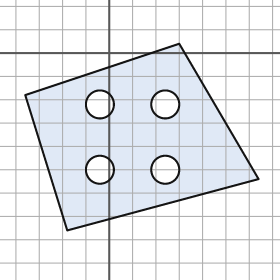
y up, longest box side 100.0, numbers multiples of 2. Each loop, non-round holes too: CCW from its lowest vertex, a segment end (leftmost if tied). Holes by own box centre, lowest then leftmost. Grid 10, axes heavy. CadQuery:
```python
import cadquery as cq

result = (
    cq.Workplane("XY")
    .moveTo(-18.0, -76.0)
    .lineTo(64.0, -54.0)
    .lineTo(30.0, 4.0)
    .lineTo(-36.0, -18.0)
    .close()
    .moveTo(-4.0, -50.0)
    .circle(6.0)
    .moveTo(24.0, -50.0)
    .circle(6.0)
    .moveTo(-4.0, -22.0)
    .circle(6.0)
    .moveTo(24.0, -22.0)
    .circle(6.0)
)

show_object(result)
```